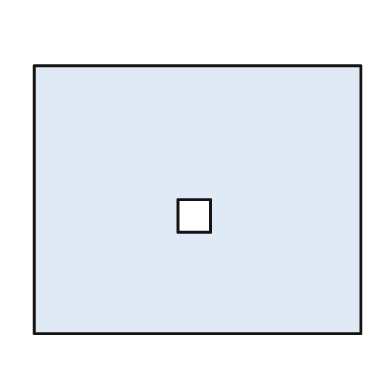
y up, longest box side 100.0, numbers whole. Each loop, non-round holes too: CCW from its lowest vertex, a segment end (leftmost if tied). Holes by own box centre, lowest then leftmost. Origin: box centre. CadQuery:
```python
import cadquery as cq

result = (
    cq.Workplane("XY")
    .moveTo(-50.0, -41.0)
    .lineTo(50.0, -41.0)
    .lineTo(50.0, 41.0)
    .lineTo(-50.0, 41.0)
    .close()
    .moveTo(-6.0, -10.0)
    .lineTo(4.0, -10.0)
    .lineTo(4.0, 0.0)
    .lineTo(-6.0, 0.0)
    .close()
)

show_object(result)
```